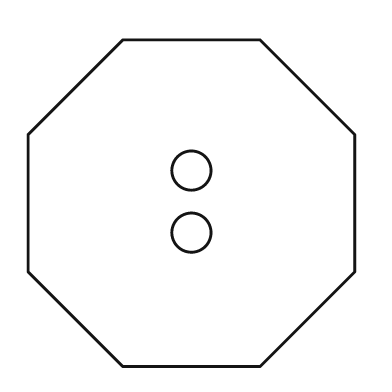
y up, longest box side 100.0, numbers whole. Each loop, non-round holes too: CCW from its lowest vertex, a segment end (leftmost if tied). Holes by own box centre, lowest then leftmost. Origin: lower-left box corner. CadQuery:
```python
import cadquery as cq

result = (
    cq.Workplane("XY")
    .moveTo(29.0, 0.0)
    .lineTo(71.0, 0.0)
    .lineTo(100.0, 29.0)
    .lineTo(100.0, 71.0)
    .lineTo(71.0, 100.0)
    .lineTo(29.0, 100.0)
    .lineTo(0.0, 71.0)
    .lineTo(0.0, 29.0)
    .close()
    .moveTo(50.0, 41.0)
    .circle(6.0)
    .moveTo(50.0, 60.0)
    .circle(6.0)
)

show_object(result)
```